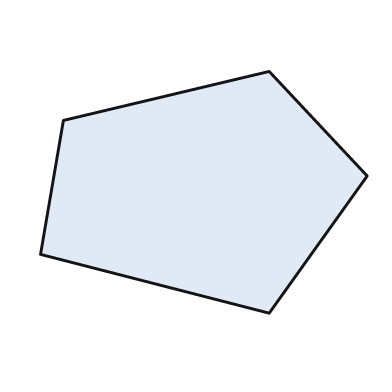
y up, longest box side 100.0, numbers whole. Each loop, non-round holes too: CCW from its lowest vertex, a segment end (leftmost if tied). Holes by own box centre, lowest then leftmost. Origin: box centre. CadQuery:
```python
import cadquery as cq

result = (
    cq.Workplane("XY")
    .moveTo(20.0, -37.0)
    .lineTo(50.0, 5.0)
    .lineTo(20.0, 37.0)
    .lineTo(-43.0, 22.0)
    .lineTo(-50.0, -19.0)
    .close()
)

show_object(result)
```